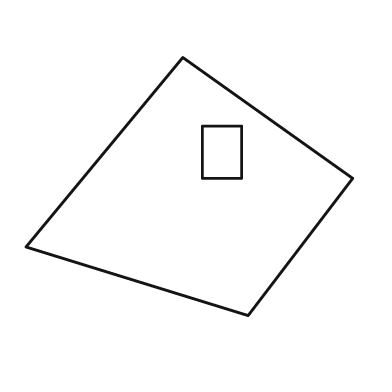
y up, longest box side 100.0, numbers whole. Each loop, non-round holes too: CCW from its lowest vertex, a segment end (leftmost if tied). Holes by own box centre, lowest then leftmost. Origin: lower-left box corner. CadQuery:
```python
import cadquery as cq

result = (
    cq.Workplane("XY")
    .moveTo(68.0, 0.0)
    .lineTo(100.0, 42.0)
    .lineTo(48.0, 79.0)
    .lineTo(0.0, 21.0)
    .close()
    .moveTo(54.0, 42.0)
    .lineTo(66.0, 42.0)
    .lineTo(66.0, 58.0)
    .lineTo(54.0, 58.0)
    .close()
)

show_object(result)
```